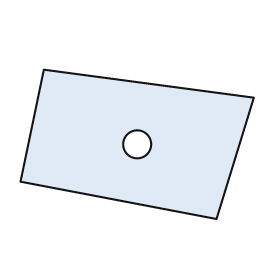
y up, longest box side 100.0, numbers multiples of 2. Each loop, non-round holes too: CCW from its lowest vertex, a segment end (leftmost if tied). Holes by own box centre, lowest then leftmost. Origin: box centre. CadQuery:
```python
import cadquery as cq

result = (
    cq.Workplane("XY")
    .moveTo(34.0, -32.0)
    .lineTo(50.0, 20.0)
    .lineTo(-40.0, 32.0)
    .lineTo(-50.0, -16.0)
    .close()
    .moveTo(0.0, 0.0)
    .circle(6.0)
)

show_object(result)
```